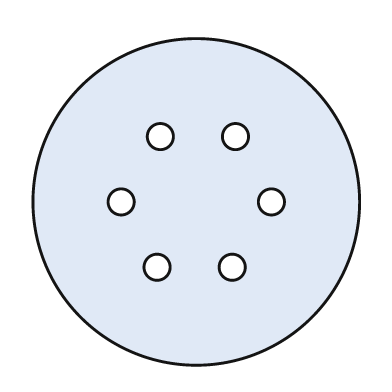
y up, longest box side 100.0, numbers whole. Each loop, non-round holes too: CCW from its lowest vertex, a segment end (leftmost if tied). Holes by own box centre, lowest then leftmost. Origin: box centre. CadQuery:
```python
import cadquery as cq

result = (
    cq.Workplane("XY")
    .moveTo(0.0, 0.0)
    .circle(50.0)
    .moveTo(-12.0, -20.0)
    .circle(4.0)
    .moveTo(11.0, -20.0)
    .circle(4.0)
    .moveTo(-23.0, 0.0)
    .circle(4.0)
    .moveTo(23.0, 0.0)
    .circle(4.0)
    .moveTo(-11.0, 20.0)
    .circle(4.0)
    .moveTo(12.0, 20.0)
    .circle(4.0)
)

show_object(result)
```